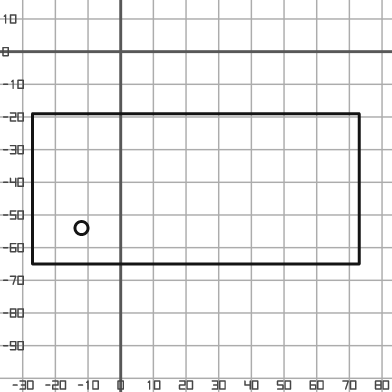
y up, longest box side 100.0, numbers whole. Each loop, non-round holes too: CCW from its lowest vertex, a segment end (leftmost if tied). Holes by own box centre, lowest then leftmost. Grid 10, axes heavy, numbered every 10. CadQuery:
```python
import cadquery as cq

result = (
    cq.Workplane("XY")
    .moveTo(-27.0, -65.0)
    .lineTo(73.0, -65.0)
    .lineTo(73.0, -19.0)
    .lineTo(-27.0, -19.0)
    .close()
    .moveTo(-12.0, -54.0)
    .circle(2.0)
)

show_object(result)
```